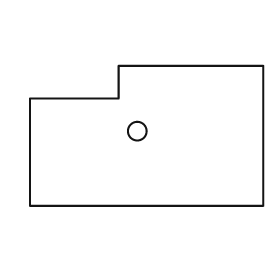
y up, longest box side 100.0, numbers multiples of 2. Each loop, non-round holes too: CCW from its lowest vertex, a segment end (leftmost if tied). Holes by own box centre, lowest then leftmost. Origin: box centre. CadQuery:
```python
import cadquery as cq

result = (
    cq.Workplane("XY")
    .moveTo(-50.0, -30.0)
    .lineTo(50.0, -30.0)
    .lineTo(50.0, 30.0)
    .lineTo(-12.0, 30.0)
    .lineTo(-12.0, 16.0)
    .lineTo(-50.0, 16.0)
    .close()
    .moveTo(-4.0, 2.0)
    .circle(4.0)
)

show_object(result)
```